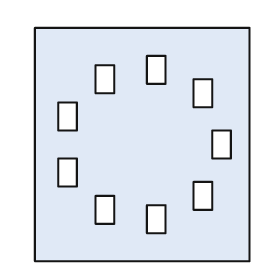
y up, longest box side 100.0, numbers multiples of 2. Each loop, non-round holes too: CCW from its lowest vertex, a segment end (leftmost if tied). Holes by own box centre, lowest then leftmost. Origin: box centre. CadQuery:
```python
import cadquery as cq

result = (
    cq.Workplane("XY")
    .moveTo(-46.0, -50.0)
    .lineTo(46.0, -50.0)
    .lineTo(46.0, 50.0)
    .lineTo(-46.0, 50.0)
    .close()
    .moveTo(2.0, -38.0)
    .lineTo(10.0, -38.0)
    .lineTo(10.0, -26.0)
    .lineTo(2.0, -26.0)
    .close()
    .moveTo(-20.0, -34.0)
    .lineTo(-12.0, -34.0)
    .lineTo(-12.0, -22.0)
    .lineTo(-20.0, -22.0)
    .close()
    .moveTo(22.0, -28.0)
    .lineTo(30.0, -28.0)
    .lineTo(30.0, -16.0)
    .lineTo(22.0, -16.0)
    .close()
    .moveTo(-36.0, -18.0)
    .lineTo(-28.0, -18.0)
    .lineTo(-28.0, -6.0)
    .lineTo(-36.0, -6.0)
    .close()
    .moveTo(30.0, -6.0)
    .lineTo(38.0, -6.0)
    .lineTo(38.0, 6.0)
    .lineTo(30.0, 6.0)
    .close()
    .moveTo(-36.0, 6.0)
    .lineTo(-28.0, 6.0)
    .lineTo(-28.0, 18.0)
    .lineTo(-36.0, 18.0)
    .close()
    .moveTo(22.0, 16.0)
    .lineTo(30.0, 16.0)
    .lineTo(30.0, 28.0)
    .lineTo(22.0, 28.0)
    .close()
    .moveTo(-20.0, 22.0)
    .lineTo(-12.0, 22.0)
    .lineTo(-12.0, 34.0)
    .lineTo(-20.0, 34.0)
    .close()
    .moveTo(2.0, 26.0)
    .lineTo(10.0, 26.0)
    .lineTo(10.0, 38.0)
    .lineTo(2.0, 38.0)
    .close()
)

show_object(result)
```